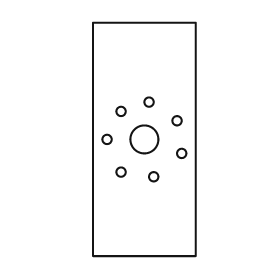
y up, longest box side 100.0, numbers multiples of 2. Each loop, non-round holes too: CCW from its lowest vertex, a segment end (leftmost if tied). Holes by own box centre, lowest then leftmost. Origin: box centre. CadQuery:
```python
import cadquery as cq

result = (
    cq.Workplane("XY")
    .moveTo(-22.0, -50.0)
    .lineTo(22.0, -50.0)
    .lineTo(22.0, 50.0)
    .lineTo(-22.0, 50.0)
    .close()
    .moveTo(4.0, -16.0)
    .circle(2.0)
    .moveTo(-10.0, -14.0)
    .circle(2.0)
    .moveTo(16.0, -6.0)
    .circle(2.0)
    .moveTo(-16.0, 0.0)
    .circle(2.0)
    .moveTo(0.0, 0.0)
    .circle(6.0)
    .moveTo(14.0, 8.0)
    .circle(2.0)
    .moveTo(-10.0, 12.0)
    .circle(2.0)
    .moveTo(2.0, 16.0)
    .circle(2.0)
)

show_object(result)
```